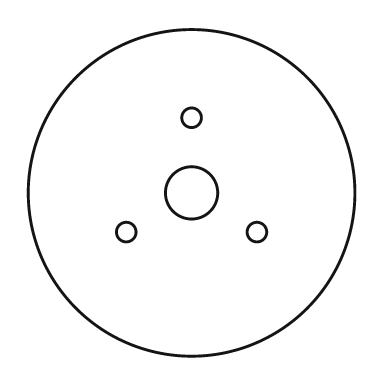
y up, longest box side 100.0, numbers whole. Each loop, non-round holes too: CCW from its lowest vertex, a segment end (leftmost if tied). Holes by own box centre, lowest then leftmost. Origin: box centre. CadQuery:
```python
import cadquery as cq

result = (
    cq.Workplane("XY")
    .moveTo(0.0, 0.0)
    .circle(50.0)
    .moveTo(-20.0, -12.0)
    .circle(3.0)
    .moveTo(20.0, -12.0)
    .circle(3.0)
    .moveTo(0.0, 0.0)
    .circle(8.0)
    .moveTo(0.0, 23.0)
    .circle(3.0)
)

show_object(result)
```